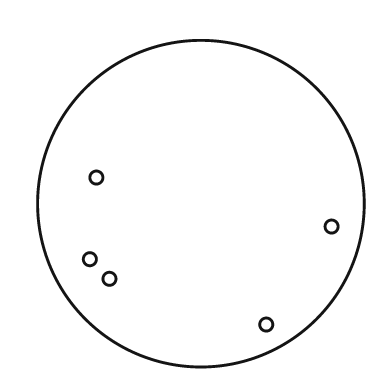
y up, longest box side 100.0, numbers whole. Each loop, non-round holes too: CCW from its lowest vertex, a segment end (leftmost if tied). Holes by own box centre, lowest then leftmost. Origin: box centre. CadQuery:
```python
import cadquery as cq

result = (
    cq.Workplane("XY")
    .moveTo(0.0, 0.0)
    .circle(50.0)
    .moveTo(20.0, -37.0)
    .circle(2.0)
    .moveTo(-28.0, -23.0)
    .circle(2.0)
    .moveTo(-34.0, -17.0)
    .circle(2.0)
    .moveTo(40.0, -7.0)
    .circle(2.0)
    .moveTo(-32.0, 8.0)
    .circle(2.0)
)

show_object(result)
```